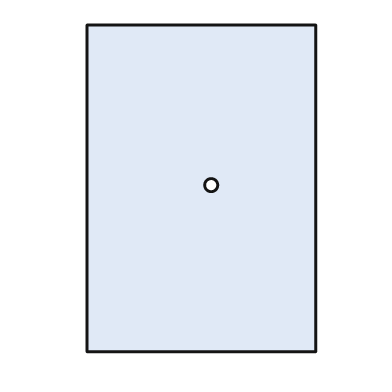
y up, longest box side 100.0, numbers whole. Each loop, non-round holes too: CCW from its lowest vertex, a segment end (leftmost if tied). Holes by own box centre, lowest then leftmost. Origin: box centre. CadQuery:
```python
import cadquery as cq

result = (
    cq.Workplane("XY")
    .moveTo(-35.0, -50.0)
    .lineTo(35.0, -50.0)
    .lineTo(35.0, 50.0)
    .lineTo(-35.0, 50.0)
    .close()
    .moveTo(3.0, 1.0)
    .circle(2.0)
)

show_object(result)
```